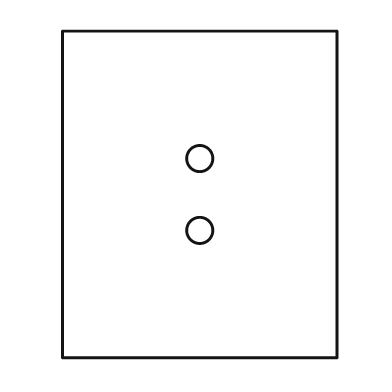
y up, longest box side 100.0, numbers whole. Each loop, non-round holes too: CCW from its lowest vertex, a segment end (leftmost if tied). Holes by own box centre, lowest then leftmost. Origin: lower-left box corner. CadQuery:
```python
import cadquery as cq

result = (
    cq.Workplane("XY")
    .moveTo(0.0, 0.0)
    .lineTo(84.0, 0.0)
    .lineTo(84.0, 100.0)
    .lineTo(0.0, 100.0)
    .close()
    .moveTo(42.0, 39.0)
    .circle(4.0)
    .moveTo(42.0, 61.0)
    .circle(4.0)
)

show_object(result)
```